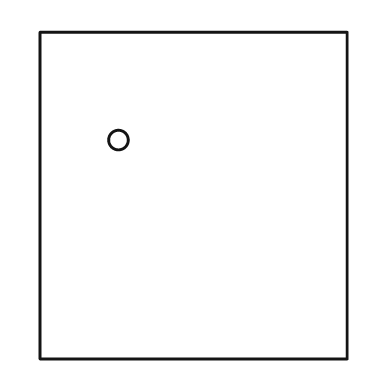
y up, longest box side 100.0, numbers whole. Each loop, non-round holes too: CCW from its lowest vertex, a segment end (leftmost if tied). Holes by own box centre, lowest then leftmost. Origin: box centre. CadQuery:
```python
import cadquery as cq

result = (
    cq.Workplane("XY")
    .moveTo(-47.0, -50.0)
    .lineTo(47.0, -50.0)
    .lineTo(47.0, 50.0)
    .lineTo(-47.0, 50.0)
    .close()
    .moveTo(-23.0, 17.0)
    .circle(3.0)
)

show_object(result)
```